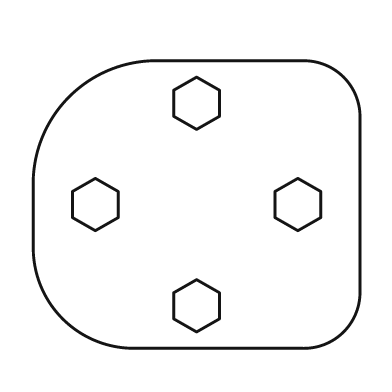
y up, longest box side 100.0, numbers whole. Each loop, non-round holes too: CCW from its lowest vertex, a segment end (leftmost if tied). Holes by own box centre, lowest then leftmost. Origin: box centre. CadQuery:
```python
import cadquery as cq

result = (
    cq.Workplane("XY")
    .moveTo(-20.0, -44.0)
    .lineTo(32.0, -44.0)
    .threePointArc((45.0, -39.0), (50.0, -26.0))
    .lineTo(50.0, 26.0)
    .threePointArc((45.0, 39.0), (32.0, 44.0))
    .lineTo(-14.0, 44.0)
    .threePointArc((-39.0, 33.0), (-50.0, 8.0))
    .lineTo(-50.0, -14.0)
    .threePointArc((-41.0, -35.0), (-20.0, -44.0))
    .close()
    .moveTo(0.0, -39.0)
    .lineTo(7.0, -35.0)
    .lineTo(7.0, -27.0)
    .lineTo(0.0, -23.0)
    .lineTo(-7.0, -27.0)
    .lineTo(-7.0, -35.0)
    .close()
    .moveTo(-31.0, -8.0)
    .lineTo(-24.0, -4.0)
    .lineTo(-24.0, 4.0)
    .lineTo(-31.0, 8.0)
    .lineTo(-38.0, 4.0)
    .lineTo(-38.0, -4.0)
    .close()
    .moveTo(31.0, -8.0)
    .lineTo(38.0, -4.0)
    .lineTo(38.0, 4.0)
    .lineTo(31.0, 8.0)
    .lineTo(24.0, 4.0)
    .lineTo(24.0, -4.0)
    .close()
    .moveTo(0.0, 23.0)
    .lineTo(7.0, 27.0)
    .lineTo(7.0, 35.0)
    .lineTo(0.0, 39.0)
    .lineTo(-7.0, 35.0)
    .lineTo(-7.0, 27.0)
    .close()
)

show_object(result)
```